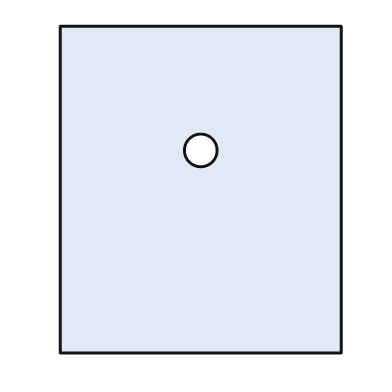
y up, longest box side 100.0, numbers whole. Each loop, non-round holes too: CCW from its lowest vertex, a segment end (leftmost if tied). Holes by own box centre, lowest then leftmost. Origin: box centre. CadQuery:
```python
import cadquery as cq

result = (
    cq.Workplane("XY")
    .moveTo(-43.0, -50.0)
    .lineTo(43.0, -50.0)
    .lineTo(43.0, 50.0)
    .lineTo(-43.0, 50.0)
    .close()
    .moveTo(0.0, 12.0)
    .circle(5.0)
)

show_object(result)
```